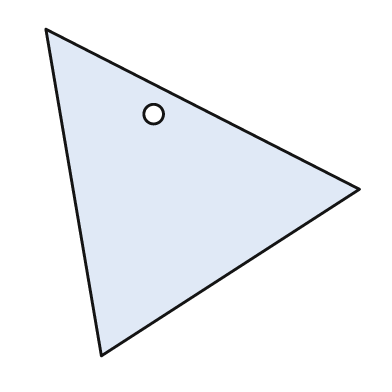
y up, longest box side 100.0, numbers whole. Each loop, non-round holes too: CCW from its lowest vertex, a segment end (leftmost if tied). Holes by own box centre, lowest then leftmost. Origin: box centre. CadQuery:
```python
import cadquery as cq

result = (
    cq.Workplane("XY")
    .moveTo(-31.0, -50.0)
    .lineTo(48.0, 1.0)
    .lineTo(-48.0, 50.0)
    .close()
    .moveTo(-15.0, 24.0)
    .circle(3.0)
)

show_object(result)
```